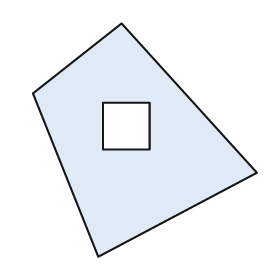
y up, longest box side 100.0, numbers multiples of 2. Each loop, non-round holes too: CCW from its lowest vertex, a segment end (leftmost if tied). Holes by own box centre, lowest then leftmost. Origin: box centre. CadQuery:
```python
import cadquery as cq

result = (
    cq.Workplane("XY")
    .moveTo(-20.0, -50.0)
    .lineTo(48.0, -14.0)
    .lineTo(-10.0, 50.0)
    .lineTo(-48.0, 20.0)
    .close()
    .moveTo(-18.0, -4.0)
    .lineTo(2.0, -4.0)
    .lineTo(2.0, 16.0)
    .lineTo(-18.0, 16.0)
    .close()
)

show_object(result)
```